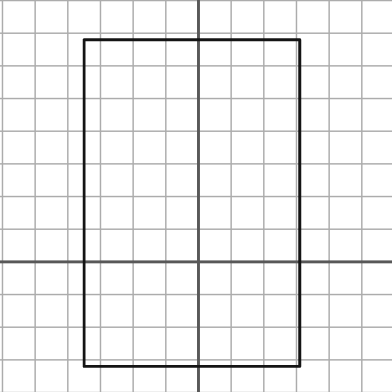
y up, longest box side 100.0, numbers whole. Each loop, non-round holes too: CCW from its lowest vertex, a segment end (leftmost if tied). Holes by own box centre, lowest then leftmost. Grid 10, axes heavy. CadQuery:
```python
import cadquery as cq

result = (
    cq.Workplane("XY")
    .moveTo(-35.0, -32.0)
    .lineTo(31.0, -32.0)
    .lineTo(31.0, 68.0)
    .lineTo(-35.0, 68.0)
    .close()
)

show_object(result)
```